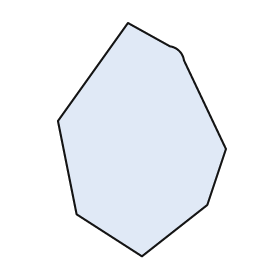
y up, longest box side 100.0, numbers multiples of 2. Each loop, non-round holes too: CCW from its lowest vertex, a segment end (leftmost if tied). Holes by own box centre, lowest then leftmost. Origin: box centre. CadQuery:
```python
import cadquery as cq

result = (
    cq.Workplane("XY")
    .moveTo(0.0, -50.0)
    .lineTo(28.0, -28.0)
    .lineTo(36.0, -4.0)
    .lineTo(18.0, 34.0)
    .threePointArc((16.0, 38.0), (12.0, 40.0))
    .lineTo(-6.0, 50.0)
    .lineTo(-36.0, 8.0)
    .lineTo(-28.0, -32.0)
    .close()
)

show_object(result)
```